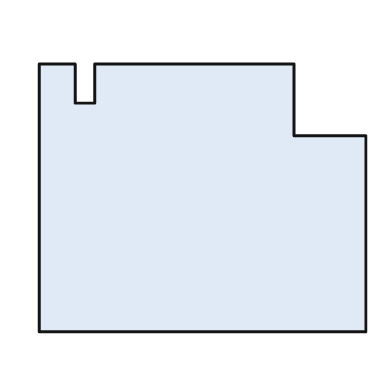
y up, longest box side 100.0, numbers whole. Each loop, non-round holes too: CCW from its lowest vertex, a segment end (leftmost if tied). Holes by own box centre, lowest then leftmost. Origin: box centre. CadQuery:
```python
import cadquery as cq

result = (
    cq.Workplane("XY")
    .moveTo(-50.0, -41.0)
    .lineTo(50.0, -41.0)
    .lineTo(50.0, 19.0)
    .lineTo(28.0, 19.0)
    .lineTo(28.0, 41.0)
    .lineTo(-33.0, 41.0)
    .lineTo(-33.0, 29.0)
    .lineTo(-39.0, 29.0)
    .lineTo(-39.0, 41.0)
    .lineTo(-50.0, 41.0)
    .close()
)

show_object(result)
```